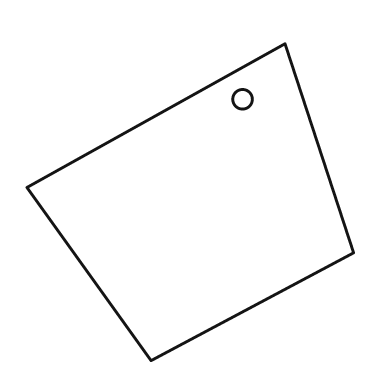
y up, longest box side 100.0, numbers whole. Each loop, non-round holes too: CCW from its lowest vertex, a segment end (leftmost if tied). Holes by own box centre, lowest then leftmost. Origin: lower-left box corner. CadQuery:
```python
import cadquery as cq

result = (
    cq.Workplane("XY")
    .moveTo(38.0, 0.0)
    .lineTo(100.0, 33.0)
    .lineTo(79.0, 97.0)
    .lineTo(0.0, 53.0)
    .close()
    .moveTo(66.0, 80.0)
    .circle(3.0)
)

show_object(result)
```